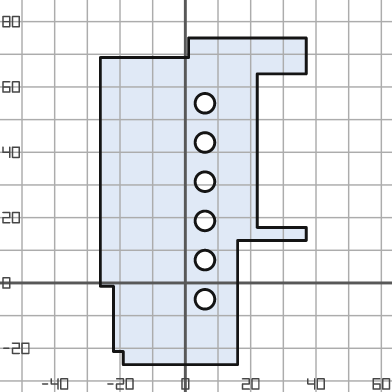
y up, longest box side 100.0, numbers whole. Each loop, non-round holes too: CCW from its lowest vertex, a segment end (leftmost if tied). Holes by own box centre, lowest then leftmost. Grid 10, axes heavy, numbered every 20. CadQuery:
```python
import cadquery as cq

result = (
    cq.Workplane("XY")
    .moveTo(-19.0, -25.0)
    .lineTo(16.0, -25.0)
    .lineTo(16.0, 13.0)
    .lineTo(37.0, 13.0)
    .lineTo(37.0, 17.0)
    .lineTo(22.0, 17.0)
    .lineTo(22.0, 64.0)
    .lineTo(37.0, 64.0)
    .lineTo(37.0, 75.0)
    .lineTo(1.0, 75.0)
    .lineTo(1.0, 69.0)
    .lineTo(-26.0, 69.0)
    .lineTo(-26.0, -1.0)
    .lineTo(-22.0, -1.0)
    .lineTo(-22.0, -21.0)
    .lineTo(-19.0, -21.0)
    .close()
    .moveTo(6.0, -5.0)
    .circle(3.0)
    .moveTo(6.0, 7.0)
    .circle(3.0)
    .moveTo(6.0, 19.0)
    .circle(3.0)
    .moveTo(6.0, 31.0)
    .circle(3.0)
    .moveTo(6.0, 43.0)
    .circle(3.0)
    .moveTo(6.0, 55.0)
    .circle(3.0)
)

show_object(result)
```